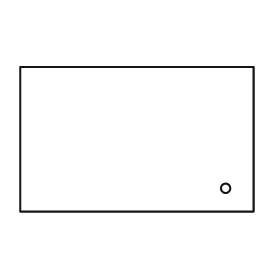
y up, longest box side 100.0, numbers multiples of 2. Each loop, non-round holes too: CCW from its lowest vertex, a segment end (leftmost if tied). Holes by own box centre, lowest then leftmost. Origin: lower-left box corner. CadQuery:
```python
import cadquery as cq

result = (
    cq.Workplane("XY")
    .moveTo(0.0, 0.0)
    .lineTo(100.0, 0.0)
    .lineTo(100.0, 62.0)
    .lineTo(0.0, 62.0)
    .close()
    .moveTo(88.0, 10.0)
    .circle(2.0)
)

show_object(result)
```